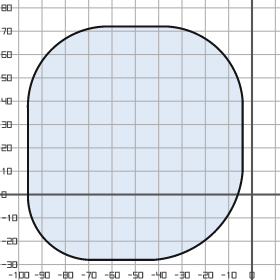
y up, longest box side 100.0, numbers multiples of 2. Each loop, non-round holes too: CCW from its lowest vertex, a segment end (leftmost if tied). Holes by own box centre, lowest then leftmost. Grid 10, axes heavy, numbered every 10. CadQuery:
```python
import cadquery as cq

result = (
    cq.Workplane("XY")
    .moveTo(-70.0, -28.0)
    .lineTo(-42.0, -28.0)
    .threePointArc((-16.0, -16.0), (-4.0, 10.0))
    .lineTo(-4.0, 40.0)
    .threePointArc((-14.0, 62.0), (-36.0, 72.0))
    .lineTo(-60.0, 72.0)
    .threePointArc((-86.0, 62.0), (-96.0, 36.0))
    .lineTo(-96.0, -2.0)
    .threePointArc((-88.0, -20.0), (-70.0, -28.0))
    .close()
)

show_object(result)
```